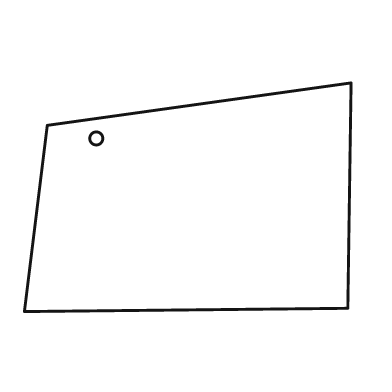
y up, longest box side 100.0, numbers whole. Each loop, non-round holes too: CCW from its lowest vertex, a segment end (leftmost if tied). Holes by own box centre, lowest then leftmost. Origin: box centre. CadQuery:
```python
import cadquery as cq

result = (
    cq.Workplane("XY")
    .moveTo(-50.0, -35.0)
    .lineTo(49.0, -34.0)
    .lineTo(50.0, 35.0)
    .lineTo(-43.0, 22.0)
    .close()
    .moveTo(-28.0, 18.0)
    .circle(2.0)
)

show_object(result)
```